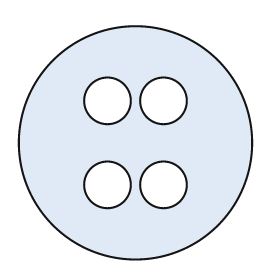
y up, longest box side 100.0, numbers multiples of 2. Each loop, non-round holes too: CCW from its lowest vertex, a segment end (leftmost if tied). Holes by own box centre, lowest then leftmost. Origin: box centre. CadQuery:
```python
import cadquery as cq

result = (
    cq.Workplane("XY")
    .moveTo(0.0, 0.0)
    .circle(50.0)
    .moveTo(-12.0, -18.0)
    .circle(10.0)
    .moveTo(12.0, -18.0)
    .circle(10.0)
    .moveTo(-12.0, 18.0)
    .circle(10.0)
    .moveTo(12.0, 18.0)
    .circle(10.0)
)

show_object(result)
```